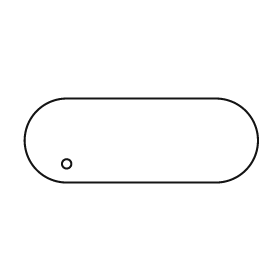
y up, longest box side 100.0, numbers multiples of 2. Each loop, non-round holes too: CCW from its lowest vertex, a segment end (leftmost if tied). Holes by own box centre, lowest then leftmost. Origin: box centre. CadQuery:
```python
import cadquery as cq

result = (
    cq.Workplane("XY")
    .moveTo(-32.0, -18.0)
    .lineTo(32.0, -18.0)
    .threePointArc((50.0, 0.0), (32.0, 18.0))
    .lineTo(-32.0, 18.0)
    .threePointArc((-50.0, 0.0), (-32.0, -18.0))
    .close()
    .moveTo(-32.0, -10.0)
    .circle(2.0)
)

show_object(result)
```